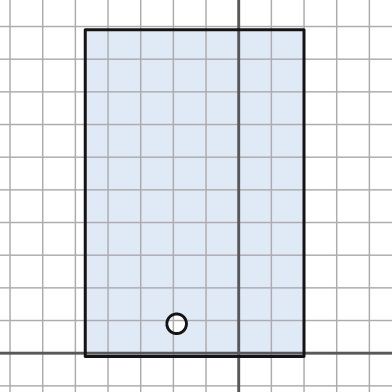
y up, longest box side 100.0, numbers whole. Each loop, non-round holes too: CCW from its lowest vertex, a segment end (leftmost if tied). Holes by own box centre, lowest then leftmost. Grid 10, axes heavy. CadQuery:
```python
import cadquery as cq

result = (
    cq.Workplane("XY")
    .moveTo(-47.0, -1.0)
    .lineTo(20.0, -1.0)
    .lineTo(20.0, 99.0)
    .lineTo(-47.0, 99.0)
    .close()
    .moveTo(-19.0, 9.0)
    .circle(3.0)
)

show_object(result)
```